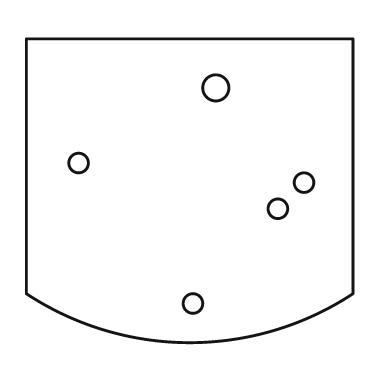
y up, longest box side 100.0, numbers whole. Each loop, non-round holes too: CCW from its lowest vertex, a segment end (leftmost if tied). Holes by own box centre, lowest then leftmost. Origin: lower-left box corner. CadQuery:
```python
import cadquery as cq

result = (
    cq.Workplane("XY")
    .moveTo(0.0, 15.0)
    .threePointArc((50.0, 0.0), (100.0, 15.0))
    .lineTo(100.0, 93.0)
    .lineTo(0.0, 93.0)
    .close()
    .moveTo(51.0, 12.0)
    .circle(3.0)
    .moveTo(77.0, 41.0)
    .circle(3.0)
    .moveTo(85.0, 49.0)
    .circle(3.0)
    .moveTo(16.0, 55.0)
    .circle(3.0)
    .moveTo(58.0, 78.0)
    .circle(4.0)
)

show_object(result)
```